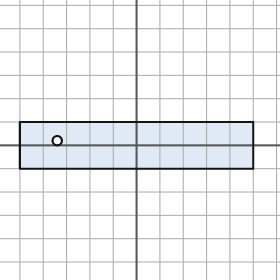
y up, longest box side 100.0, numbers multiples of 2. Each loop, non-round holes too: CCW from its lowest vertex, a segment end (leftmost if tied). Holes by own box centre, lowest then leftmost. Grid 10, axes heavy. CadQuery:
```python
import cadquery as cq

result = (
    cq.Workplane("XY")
    .moveTo(-50.0, -10.0)
    .lineTo(50.0, -10.0)
    .lineTo(50.0, 10.0)
    .lineTo(-50.0, 10.0)
    .close()
    .moveTo(-34.0, 2.0)
    .circle(2.0)
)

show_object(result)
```